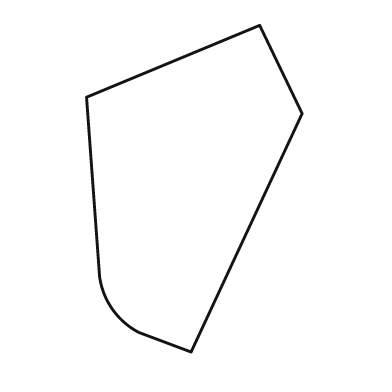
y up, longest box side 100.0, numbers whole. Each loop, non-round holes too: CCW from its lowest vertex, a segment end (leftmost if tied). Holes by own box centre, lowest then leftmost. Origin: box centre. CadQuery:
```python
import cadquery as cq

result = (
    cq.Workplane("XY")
    .moveTo(-1.0, -50.0)
    .lineTo(33.0, 23.0)
    .lineTo(20.0, 50.0)
    .lineTo(-33.0, 28.0)
    .lineTo(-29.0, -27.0)
    .threePointArc((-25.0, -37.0), (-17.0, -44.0))
    .close()
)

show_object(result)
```